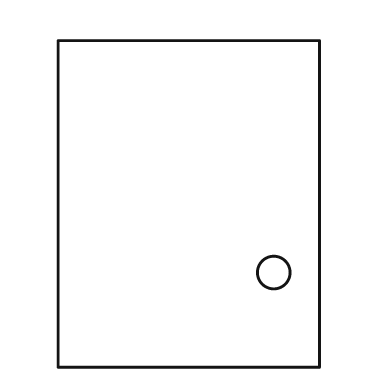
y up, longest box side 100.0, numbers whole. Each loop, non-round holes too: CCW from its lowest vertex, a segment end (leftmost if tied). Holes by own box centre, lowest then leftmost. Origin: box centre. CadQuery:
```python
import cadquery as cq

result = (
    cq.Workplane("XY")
    .moveTo(-40.0, -50.0)
    .lineTo(40.0, -50.0)
    .lineTo(40.0, 50.0)
    .lineTo(-40.0, 50.0)
    .close()
    .moveTo(26.0, -21.0)
    .circle(5.0)
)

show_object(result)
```